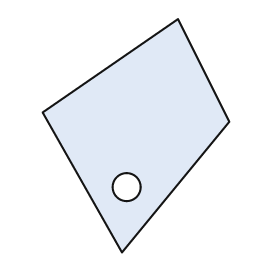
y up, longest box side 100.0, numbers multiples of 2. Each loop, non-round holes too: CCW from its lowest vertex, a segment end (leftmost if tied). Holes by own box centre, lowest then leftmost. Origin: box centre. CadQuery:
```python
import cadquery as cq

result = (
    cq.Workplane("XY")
    .moveTo(-6.0, -50.0)
    .lineTo(40.0, 6.0)
    .lineTo(18.0, 50.0)
    .lineTo(-40.0, 10.0)
    .close()
    .moveTo(-4.0, -22.0)
    .circle(6.0)
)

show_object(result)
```